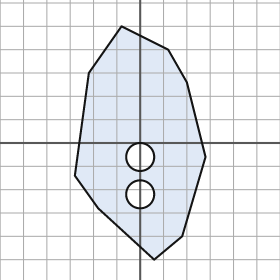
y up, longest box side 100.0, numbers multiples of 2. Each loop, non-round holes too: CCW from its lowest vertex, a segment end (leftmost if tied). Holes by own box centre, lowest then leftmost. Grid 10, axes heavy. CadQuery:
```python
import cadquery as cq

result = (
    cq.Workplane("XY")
    .moveTo(6.0, -50.0)
    .lineTo(18.0, -40.0)
    .lineTo(28.0, -6.0)
    .lineTo(20.0, 26.0)
    .lineTo(12.0, 40.0)
    .lineTo(-8.0, 50.0)
    .lineTo(-22.0, 30.0)
    .lineTo(-28.0, -14.0)
    .lineTo(-18.0, -28.0)
    .close()
    .moveTo(0.0, -22.0)
    .circle(6.0)
    .moveTo(0.0, -6.0)
    .circle(6.0)
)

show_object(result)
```